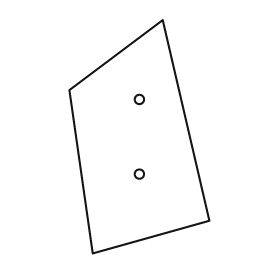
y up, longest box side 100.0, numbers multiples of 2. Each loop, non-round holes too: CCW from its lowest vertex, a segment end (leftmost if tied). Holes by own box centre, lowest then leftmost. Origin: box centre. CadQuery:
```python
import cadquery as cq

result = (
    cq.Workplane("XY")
    .moveTo(-20.0, -50.0)
    .lineTo(30.0, -36.0)
    .lineTo(10.0, 50.0)
    .lineTo(-30.0, 20.0)
    .close()
    .moveTo(0.0, -16.0)
    .circle(2.0)
    .moveTo(0.0, 16.0)
    .circle(2.0)
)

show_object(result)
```